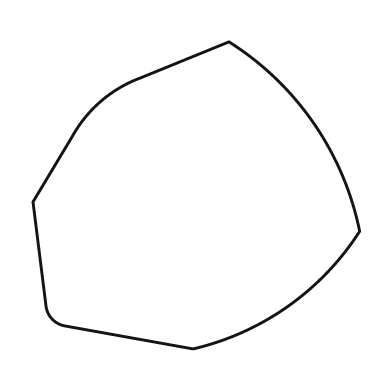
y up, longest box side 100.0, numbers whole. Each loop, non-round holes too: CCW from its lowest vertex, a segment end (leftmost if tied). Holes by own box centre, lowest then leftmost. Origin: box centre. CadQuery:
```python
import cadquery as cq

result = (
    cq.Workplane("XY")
    .moveTo(-1.0, -47.0)
    .threePointArc((28.0, -34.0), (50.0, -11.0))
    .threePointArc((36.0, 22.0), (10.0, 47.0))
    .lineTo(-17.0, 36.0)
    .threePointArc((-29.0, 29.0), (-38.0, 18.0))
    .lineTo(-50.0, -2.0)
    .lineTo(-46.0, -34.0)
    .threePointArc((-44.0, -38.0), (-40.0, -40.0))
    .close()
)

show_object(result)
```